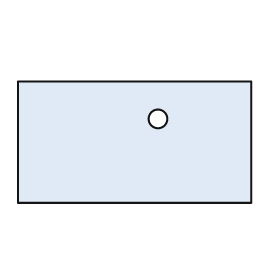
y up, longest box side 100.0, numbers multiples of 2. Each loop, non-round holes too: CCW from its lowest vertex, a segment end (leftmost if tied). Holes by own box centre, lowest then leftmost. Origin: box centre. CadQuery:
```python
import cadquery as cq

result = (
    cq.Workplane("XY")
    .moveTo(-50.0, -26.0)
    .lineTo(50.0, -26.0)
    .lineTo(50.0, 26.0)
    .lineTo(-50.0, 26.0)
    .close()
    .moveTo(10.0, 10.0)
    .circle(4.0)
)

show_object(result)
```